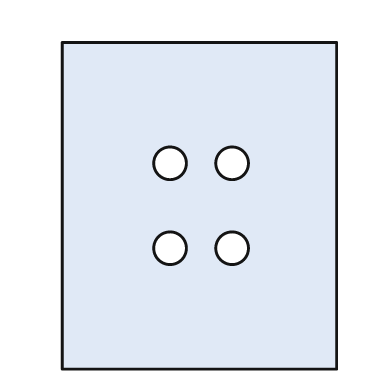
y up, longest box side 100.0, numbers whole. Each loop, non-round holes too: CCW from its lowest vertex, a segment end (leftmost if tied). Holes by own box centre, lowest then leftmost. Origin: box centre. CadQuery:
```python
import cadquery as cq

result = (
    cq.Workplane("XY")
    .moveTo(-42.0, -50.0)
    .lineTo(42.0, -50.0)
    .lineTo(42.0, 50.0)
    .lineTo(-42.0, 50.0)
    .close()
    .moveTo(-9.0, -13.0)
    .circle(5.0)
    .moveTo(10.0, -13.0)
    .circle(5.0)
    .moveTo(-9.0, 13.0)
    .circle(5.0)
    .moveTo(10.0, 13.0)
    .circle(5.0)
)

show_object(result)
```